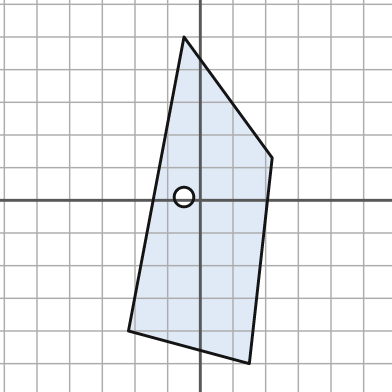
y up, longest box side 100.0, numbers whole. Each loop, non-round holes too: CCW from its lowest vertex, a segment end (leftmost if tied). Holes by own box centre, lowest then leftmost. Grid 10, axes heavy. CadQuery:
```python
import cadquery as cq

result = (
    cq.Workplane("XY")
    .moveTo(15.0, -50.0)
    .lineTo(22.0, 13.0)
    .lineTo(-5.0, 50.0)
    .lineTo(-22.0, -40.0)
    .close()
    .moveTo(-5.0, 1.0)
    .circle(3.0)
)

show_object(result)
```